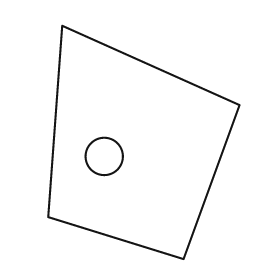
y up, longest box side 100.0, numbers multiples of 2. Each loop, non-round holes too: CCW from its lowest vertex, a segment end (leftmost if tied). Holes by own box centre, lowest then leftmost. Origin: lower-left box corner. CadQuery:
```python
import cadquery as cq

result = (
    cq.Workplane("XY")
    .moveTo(58.0, 0.0)
    .lineTo(82.0, 66.0)
    .lineTo(6.0, 100.0)
    .lineTo(0.0, 18.0)
    .close()
    .moveTo(24.0, 44.0)
    .circle(8.0)
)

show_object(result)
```